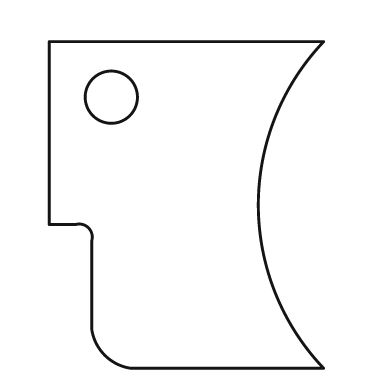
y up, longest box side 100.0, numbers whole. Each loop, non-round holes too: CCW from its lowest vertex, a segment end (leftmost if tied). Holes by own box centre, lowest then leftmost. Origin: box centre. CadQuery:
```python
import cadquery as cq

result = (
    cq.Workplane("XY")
    .moveTo(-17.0, -50.0)
    .lineTo(42.0, -50.0)
    .threePointArc((22.0, 0.0), (42.0, 50.0))
    .lineTo(-42.0, 50.0)
    .lineTo(-42.0, -6.0)
    .lineTo(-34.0, -6.0)
    .threePointArc((-30.0, -7.0), (-29.0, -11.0))
    .lineTo(-29.0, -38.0)
    .threePointArc((-25.0, -46.0), (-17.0, -50.0))
    .close()
    .moveTo(-23.0, 33.0)
    .circle(8.0)
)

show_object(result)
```